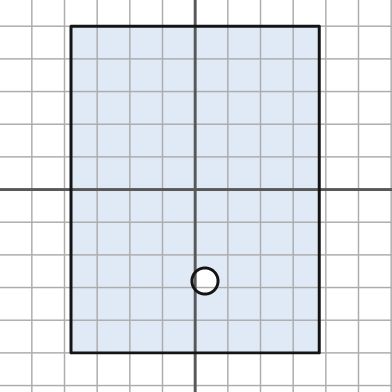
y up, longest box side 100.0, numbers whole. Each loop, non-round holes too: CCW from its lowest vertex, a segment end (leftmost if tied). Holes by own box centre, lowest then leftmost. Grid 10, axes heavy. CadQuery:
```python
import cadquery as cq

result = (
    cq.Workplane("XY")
    .moveTo(-38.0, -50.0)
    .lineTo(38.0, -50.0)
    .lineTo(38.0, 50.0)
    .lineTo(-38.0, 50.0)
    .close()
    .moveTo(3.0, -28.0)
    .circle(4.0)
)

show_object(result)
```